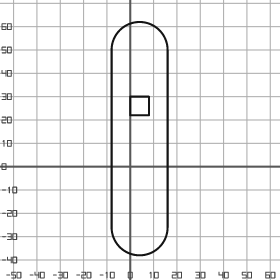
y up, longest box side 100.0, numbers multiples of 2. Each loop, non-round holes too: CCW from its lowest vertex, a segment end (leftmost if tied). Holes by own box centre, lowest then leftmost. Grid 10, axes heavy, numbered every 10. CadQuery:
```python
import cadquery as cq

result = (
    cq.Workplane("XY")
    .moveTo(-8.0, -26.0)
    .threePointArc((4.0, -38.0), (16.0, -26.0))
    .lineTo(16.0, 50.0)
    .threePointArc((4.0, 62.0), (-8.0, 50.0))
    .close()
    .moveTo(0.0, 22.0)
    .lineTo(8.0, 22.0)
    .lineTo(8.0, 30.0)
    .lineTo(0.0, 30.0)
    .close()
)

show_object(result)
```